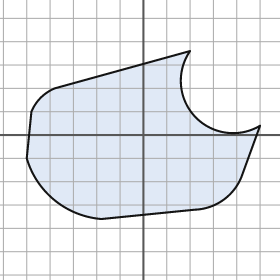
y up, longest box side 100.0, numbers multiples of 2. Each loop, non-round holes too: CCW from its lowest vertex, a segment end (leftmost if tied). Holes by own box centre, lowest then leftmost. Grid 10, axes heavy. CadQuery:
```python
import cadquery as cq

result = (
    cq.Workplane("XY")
    .moveTo(-18.0, -36.0)
    .lineTo(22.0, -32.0)
    .threePointArc((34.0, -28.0), (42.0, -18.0))
    .lineTo(50.0, 4.0)
    .threePointArc((22.0, 8.0), (20.0, 36.0))
    .lineTo(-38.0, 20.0)
    .threePointArc((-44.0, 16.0), (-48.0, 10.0))
    .lineTo(-50.0, -10.0)
    .threePointArc((-38.0, -28.0), (-18.0, -36.0))
    .close()
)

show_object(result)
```